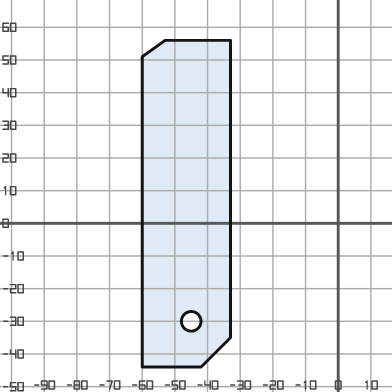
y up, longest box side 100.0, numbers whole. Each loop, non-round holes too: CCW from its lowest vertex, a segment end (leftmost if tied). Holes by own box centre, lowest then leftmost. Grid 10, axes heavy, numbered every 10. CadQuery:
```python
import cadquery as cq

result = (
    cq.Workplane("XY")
    .moveTo(-60.0, -44.0)
    .lineTo(-42.0, -44.0)
    .lineTo(-33.0, -35.0)
    .lineTo(-33.0, 56.0)
    .lineTo(-53.0, 56.0)
    .lineTo(-60.0, 51.0)
    .close()
    .moveTo(-45.0, -30.0)
    .circle(3.0)
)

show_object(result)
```